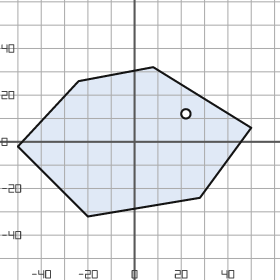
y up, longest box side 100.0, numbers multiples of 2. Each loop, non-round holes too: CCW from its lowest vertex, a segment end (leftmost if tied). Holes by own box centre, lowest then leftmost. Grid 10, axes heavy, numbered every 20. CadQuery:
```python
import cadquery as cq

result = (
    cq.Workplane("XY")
    .moveTo(-20.0, -32.0)
    .lineTo(28.0, -24.0)
    .lineTo(50.0, 6.0)
    .lineTo(8.0, 32.0)
    .lineTo(-24.0, 26.0)
    .lineTo(-50.0, -2.0)
    .close()
    .moveTo(22.0, 12.0)
    .circle(2.0)
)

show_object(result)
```